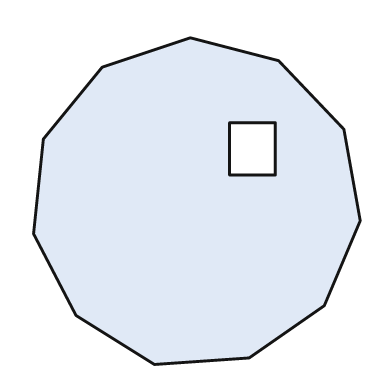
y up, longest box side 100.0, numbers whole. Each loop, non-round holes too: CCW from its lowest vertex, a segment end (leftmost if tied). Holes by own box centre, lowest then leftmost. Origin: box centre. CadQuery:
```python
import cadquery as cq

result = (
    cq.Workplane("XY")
    .moveTo(-13.0, -50.0)
    .lineTo(16.0, -48.0)
    .lineTo(39.0, -32.0)
    .lineTo(50.0, -6.0)
    .lineTo(45.0, 22.0)
    .lineTo(25.0, 43.0)
    .lineTo(-2.0, 50.0)
    .lineTo(-29.0, 41.0)
    .lineTo(-47.0, 19.0)
    .lineTo(-50.0, -10.0)
    .lineTo(-37.0, -35.0)
    .close()
    .moveTo(10.0, 8.0)
    .lineTo(24.0, 8.0)
    .lineTo(24.0, 24.0)
    .lineTo(10.0, 24.0)
    .close()
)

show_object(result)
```